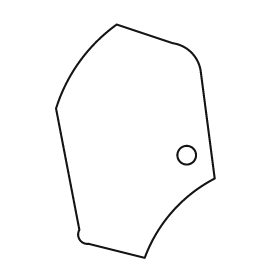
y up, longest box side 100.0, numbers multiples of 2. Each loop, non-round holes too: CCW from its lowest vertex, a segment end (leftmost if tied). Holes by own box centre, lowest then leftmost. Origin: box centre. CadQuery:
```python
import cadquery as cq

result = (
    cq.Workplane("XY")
    .moveTo(4.0, -50.0)
    .threePointArc((16.0, -30.0), (34.0, -16.0))
    .lineTo(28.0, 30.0)
    .threePointArc((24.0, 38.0), (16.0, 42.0))
    .lineTo(-8.0, 50.0)
    .threePointArc((-24.0, 34.0), (-34.0, 14.0))
    .lineTo(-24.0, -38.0)
    .threePointArc((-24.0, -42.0), (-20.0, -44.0))
    .close()
    .moveTo(22.0, -6.0)
    .circle(4.0)
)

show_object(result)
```